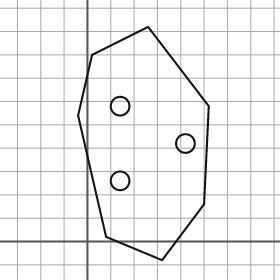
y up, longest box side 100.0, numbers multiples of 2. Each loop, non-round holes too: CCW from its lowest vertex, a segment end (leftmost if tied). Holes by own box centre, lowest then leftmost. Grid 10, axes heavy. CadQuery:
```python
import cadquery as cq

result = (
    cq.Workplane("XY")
    .moveTo(32.0, -8.0)
    .lineTo(50.0, 16.0)
    .lineTo(52.0, 58.0)
    .lineTo(26.0, 92.0)
    .lineTo(2.0, 80.0)
    .lineTo(-4.0, 54.0)
    .lineTo(8.0, 2.0)
    .close()
    .moveTo(14.0, 26.0)
    .circle(4.0)
    .moveTo(42.0, 42.0)
    .circle(4.0)
    .moveTo(14.0, 58.0)
    .circle(4.0)
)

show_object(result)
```